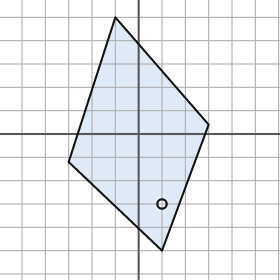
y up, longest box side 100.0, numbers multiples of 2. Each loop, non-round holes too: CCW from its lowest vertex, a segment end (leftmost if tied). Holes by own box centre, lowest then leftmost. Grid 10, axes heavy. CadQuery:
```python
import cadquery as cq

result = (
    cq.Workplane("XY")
    .moveTo(10.0, -50.0)
    .lineTo(30.0, 4.0)
    .lineTo(-10.0, 50.0)
    .lineTo(-30.0, -12.0)
    .close()
    .moveTo(10.0, -30.0)
    .circle(2.0)
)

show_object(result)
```